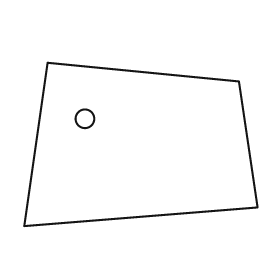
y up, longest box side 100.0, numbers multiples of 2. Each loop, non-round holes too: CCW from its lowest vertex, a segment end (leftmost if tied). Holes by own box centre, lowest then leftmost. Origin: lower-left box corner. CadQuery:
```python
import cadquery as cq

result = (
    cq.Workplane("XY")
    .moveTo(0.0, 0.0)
    .lineTo(100.0, 8.0)
    .lineTo(92.0, 62.0)
    .lineTo(10.0, 70.0)
    .close()
    .moveTo(26.0, 46.0)
    .circle(4.0)
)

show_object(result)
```